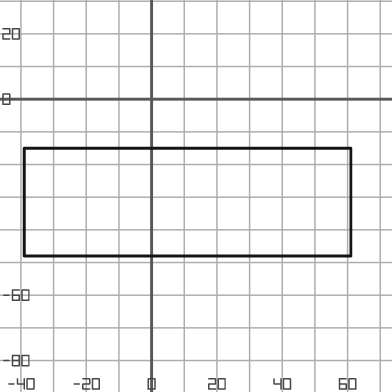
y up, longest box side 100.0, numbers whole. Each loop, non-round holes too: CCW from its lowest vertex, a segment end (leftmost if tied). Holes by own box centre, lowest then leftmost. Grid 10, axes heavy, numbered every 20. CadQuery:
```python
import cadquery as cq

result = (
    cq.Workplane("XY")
    .moveTo(-39.0, -48.0)
    .lineTo(61.0, -48.0)
    .lineTo(61.0, -15.0)
    .lineTo(-39.0, -15.0)
    .close()
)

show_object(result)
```